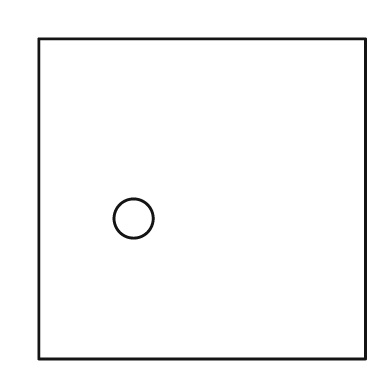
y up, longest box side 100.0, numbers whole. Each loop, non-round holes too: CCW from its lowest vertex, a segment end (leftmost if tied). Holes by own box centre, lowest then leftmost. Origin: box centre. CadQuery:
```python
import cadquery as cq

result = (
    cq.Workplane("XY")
    .moveTo(-50.0, -49.0)
    .lineTo(50.0, -49.0)
    .lineTo(50.0, 49.0)
    .lineTo(-50.0, 49.0)
    .close()
    .moveTo(-21.0, -6.0)
    .circle(6.0)
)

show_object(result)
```